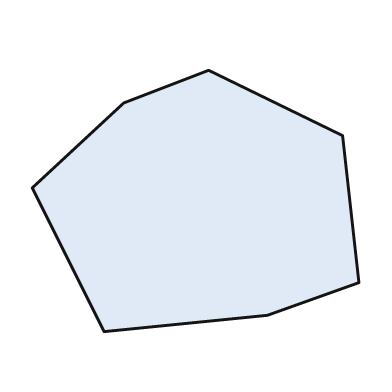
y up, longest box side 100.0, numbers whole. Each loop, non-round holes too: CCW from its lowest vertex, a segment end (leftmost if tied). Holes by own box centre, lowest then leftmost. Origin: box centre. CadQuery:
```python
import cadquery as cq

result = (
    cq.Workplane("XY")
    .moveTo(-28.0, -40.0)
    .lineTo(22.0, -35.0)
    .lineTo(50.0, -25.0)
    .lineTo(45.0, 20.0)
    .lineTo(4.0, 40.0)
    .lineTo(-22.0, 30.0)
    .lineTo(-50.0, 4.0)
    .close()
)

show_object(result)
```